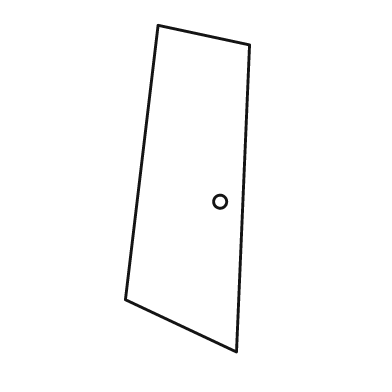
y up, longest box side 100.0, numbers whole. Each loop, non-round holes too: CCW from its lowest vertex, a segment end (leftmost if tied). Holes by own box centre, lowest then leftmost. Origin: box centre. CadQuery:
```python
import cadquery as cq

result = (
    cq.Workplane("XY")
    .moveTo(15.0, -50.0)
    .lineTo(19.0, 44.0)
    .lineTo(-9.0, 50.0)
    .lineTo(-19.0, -34.0)
    .close()
    .moveTo(10.0, -4.0)
    .circle(2.0)
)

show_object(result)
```